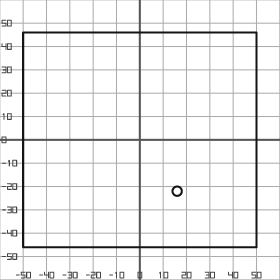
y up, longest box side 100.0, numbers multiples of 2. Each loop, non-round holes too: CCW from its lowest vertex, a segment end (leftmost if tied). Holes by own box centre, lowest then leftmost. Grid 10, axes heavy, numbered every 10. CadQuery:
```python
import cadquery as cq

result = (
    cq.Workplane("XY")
    .moveTo(-50.0, -46.0)
    .lineTo(50.0, -46.0)
    .lineTo(50.0, 46.0)
    .lineTo(-50.0, 46.0)
    .close()
    .moveTo(16.0, -22.0)
    .circle(2.0)
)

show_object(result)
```